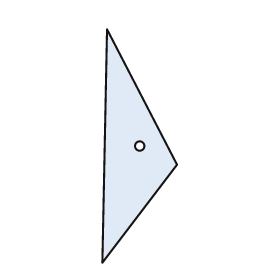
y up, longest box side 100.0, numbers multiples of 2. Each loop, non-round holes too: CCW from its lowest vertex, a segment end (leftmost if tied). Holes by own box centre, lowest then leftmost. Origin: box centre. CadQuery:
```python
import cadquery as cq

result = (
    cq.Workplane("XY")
    .moveTo(-16.0, -50.0)
    .lineTo(16.0, -8.0)
    .lineTo(-14.0, 50.0)
    .close()
    .moveTo(0.0, 0.0)
    .circle(2.0)
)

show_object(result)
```